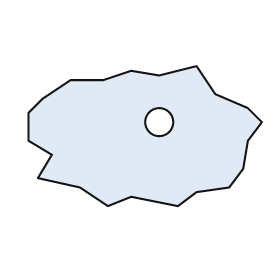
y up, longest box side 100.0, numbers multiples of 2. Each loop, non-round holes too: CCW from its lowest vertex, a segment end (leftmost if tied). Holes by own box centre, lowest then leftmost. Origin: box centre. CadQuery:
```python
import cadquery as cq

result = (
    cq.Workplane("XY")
    .moveTo(-16.0, -30.0)
    .lineTo(-6.0, -26.0)
    .lineTo(14.0, -30.0)
    .lineTo(22.0, -24.0)
    .lineTo(36.0, -22.0)
    .lineTo(42.0, -14.0)
    .lineTo(44.0, -2.0)
    .lineTo(50.0, 6.0)
    .lineTo(44.0, 12.0)
    .lineTo(30.0, 18.0)
    .lineTo(22.0, 30.0)
    .lineTo(6.0, 26.0)
    .lineTo(-6.0, 28.0)
    .lineTo(-18.0, 24.0)
    .lineTo(-32.0, 24.0)
    .lineTo(-44.0, 16.0)
    .lineTo(-50.0, 10.0)
    .lineTo(-50.0, -2.0)
    .lineTo(-40.0, -8.0)
    .lineTo(-46.0, -18.0)
    .lineTo(-28.0, -22.0)
    .close()
    .moveTo(6.0, 6.0)
    .circle(6.0)
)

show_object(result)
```